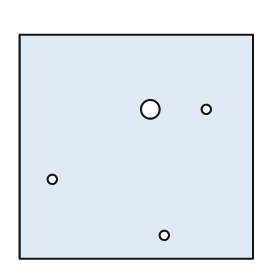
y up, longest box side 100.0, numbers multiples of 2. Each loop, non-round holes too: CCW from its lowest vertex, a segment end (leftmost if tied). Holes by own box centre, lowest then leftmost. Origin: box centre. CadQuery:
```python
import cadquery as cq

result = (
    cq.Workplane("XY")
    .moveTo(-50.0, -48.0)
    .lineTo(50.0, -48.0)
    .lineTo(50.0, 48.0)
    .lineTo(-50.0, 48.0)
    .close()
    .moveTo(12.0, -38.0)
    .circle(2.0)
    .moveTo(-36.0, -14.0)
    .circle(2.0)
    .moveTo(6.0, 16.0)
    .circle(4.0)
    .moveTo(30.0, 16.0)
    .circle(2.0)
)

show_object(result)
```